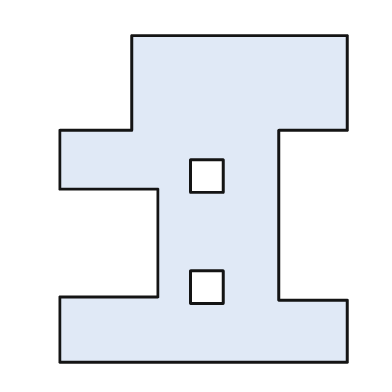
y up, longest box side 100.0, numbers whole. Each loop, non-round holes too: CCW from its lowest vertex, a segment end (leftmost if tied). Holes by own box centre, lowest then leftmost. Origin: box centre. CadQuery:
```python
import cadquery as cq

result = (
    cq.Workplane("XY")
    .moveTo(-44.0, -50.0)
    .lineTo(44.0, -50.0)
    .lineTo(44.0, -31.0)
    .lineTo(23.0, -31.0)
    .lineTo(23.0, 21.0)
    .lineTo(44.0, 21.0)
    .lineTo(44.0, 50.0)
    .lineTo(-22.0, 50.0)
    .lineTo(-22.0, 21.0)
    .lineTo(-44.0, 21.0)
    .lineTo(-44.0, 3.0)
    .lineTo(-14.0, 3.0)
    .lineTo(-14.0, -30.0)
    .lineTo(-44.0, -30.0)
    .close()
    .moveTo(-4.0, -32.0)
    .lineTo(6.0, -32.0)
    .lineTo(6.0, -22.0)
    .lineTo(-4.0, -22.0)
    .close()
    .moveTo(-4.0, 2.0)
    .lineTo(6.0, 2.0)
    .lineTo(6.0, 12.0)
    .lineTo(-4.0, 12.0)
    .close()
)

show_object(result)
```